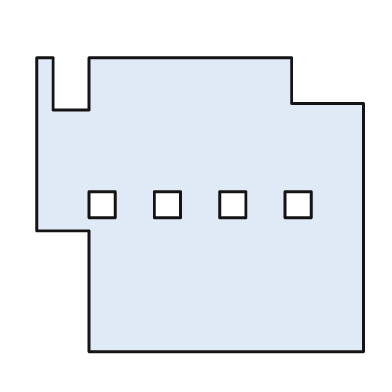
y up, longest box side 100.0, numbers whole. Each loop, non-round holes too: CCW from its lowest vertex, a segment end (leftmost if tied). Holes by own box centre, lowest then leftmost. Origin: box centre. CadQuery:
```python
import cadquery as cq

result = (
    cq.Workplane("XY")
    .moveTo(-34.0, -45.0)
    .lineTo(50.0, -45.0)
    .lineTo(50.0, 31.0)
    .lineTo(28.0, 31.0)
    .lineTo(28.0, 45.0)
    .lineTo(-34.0, 45.0)
    .lineTo(-34.0, 29.0)
    .lineTo(-45.0, 29.0)
    .lineTo(-45.0, 45.0)
    .lineTo(-50.0, 45.0)
    .lineTo(-50.0, -8.0)
    .lineTo(-34.0, -8.0)
    .close()
    .moveTo(-34.0, -4.0)
    .lineTo(-26.0, -4.0)
    .lineTo(-26.0, 4.0)
    .lineTo(-34.0, 4.0)
    .close()
    .moveTo(-14.0, -4.0)
    .lineTo(-6.0, -4.0)
    .lineTo(-6.0, 4.0)
    .lineTo(-14.0, 4.0)
    .close()
    .moveTo(6.0, -4.0)
    .lineTo(14.0, -4.0)
    .lineTo(14.0, 4.0)
    .lineTo(6.0, 4.0)
    .close()
    .moveTo(26.0, -4.0)
    .lineTo(34.0, -4.0)
    .lineTo(34.0, 4.0)
    .lineTo(26.0, 4.0)
    .close()
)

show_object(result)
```